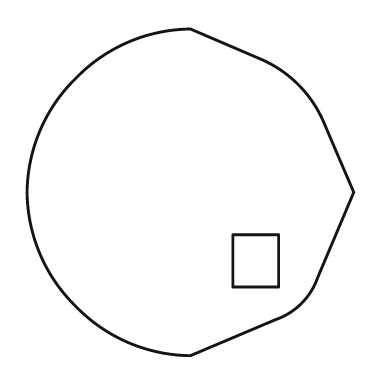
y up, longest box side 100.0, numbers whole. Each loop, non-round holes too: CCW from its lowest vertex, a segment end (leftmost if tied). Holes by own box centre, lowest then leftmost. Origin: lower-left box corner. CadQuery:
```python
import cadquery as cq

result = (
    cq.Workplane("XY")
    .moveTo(50.0, 0.0)
    .lineTo(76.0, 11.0)
    .threePointArc((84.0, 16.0), (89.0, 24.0))
    .lineTo(100.0, 50.0)
    .lineTo(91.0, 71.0)
    .threePointArc((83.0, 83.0), (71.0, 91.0))
    .lineTo(50.0, 100.0)
    .threePointArc((31.0, 96.0), (15.0, 85.0))
    .threePointArc((4.0, 69.0), (0.0, 50.0))
    .threePointArc((4.0, 31.0), (15.0, 15.0))
    .threePointArc((31.0, 4.0), (50.0, 0.0))
    .close()
    .moveTo(63.0, 21.0)
    .lineTo(77.0, 21.0)
    .lineTo(77.0, 37.0)
    .lineTo(63.0, 37.0)
    .close()
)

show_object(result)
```